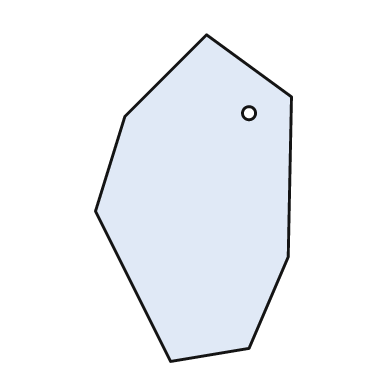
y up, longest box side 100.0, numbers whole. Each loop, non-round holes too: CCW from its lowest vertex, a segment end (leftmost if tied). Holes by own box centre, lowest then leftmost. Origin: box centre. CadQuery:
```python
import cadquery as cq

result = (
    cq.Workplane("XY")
    .moveTo(-7.0, -50.0)
    .lineTo(17.0, -46.0)
    .lineTo(29.0, -18.0)
    .lineTo(30.0, 31.0)
    .lineTo(4.0, 50.0)
    .lineTo(-21.0, 25.0)
    .lineTo(-30.0, -4.0)
    .close()
    .moveTo(17.0, 26.0)
    .circle(2.0)
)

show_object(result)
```